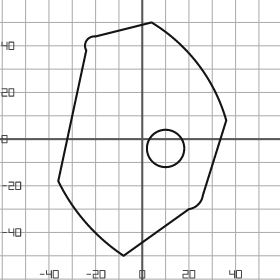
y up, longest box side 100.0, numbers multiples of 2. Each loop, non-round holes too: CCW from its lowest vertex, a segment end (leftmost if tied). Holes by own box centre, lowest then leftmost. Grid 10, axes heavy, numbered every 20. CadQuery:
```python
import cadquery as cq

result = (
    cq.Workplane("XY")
    .moveTo(-8.0, -50.0)
    .lineTo(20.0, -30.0)
    .threePointArc((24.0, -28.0), (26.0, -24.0))
    .lineTo(36.0, 8.0)
    .threePointArc((24.0, 32.0), (4.0, 50.0))
    .lineTo(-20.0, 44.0)
    .threePointArc((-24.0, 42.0), (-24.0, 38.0))
    .lineTo(-36.0, -18.0)
    .threePointArc((-24.0, -36.0), (-8.0, -50.0))
    .close()
    .moveTo(10.0, -4.0)
    .circle(8.0)
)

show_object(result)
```